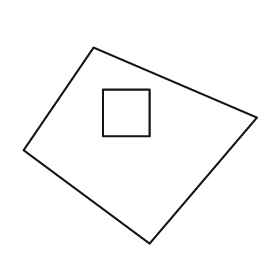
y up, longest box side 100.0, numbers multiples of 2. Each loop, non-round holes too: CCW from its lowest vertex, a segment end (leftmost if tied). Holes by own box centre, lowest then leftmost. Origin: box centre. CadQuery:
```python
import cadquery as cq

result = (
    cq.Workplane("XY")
    .moveTo(4.0, -42.0)
    .lineTo(50.0, 12.0)
    .lineTo(-20.0, 42.0)
    .lineTo(-50.0, -2.0)
    .close()
    .moveTo(-16.0, 4.0)
    .lineTo(4.0, 4.0)
    .lineTo(4.0, 24.0)
    .lineTo(-16.0, 24.0)
    .close()
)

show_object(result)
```